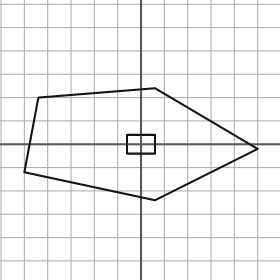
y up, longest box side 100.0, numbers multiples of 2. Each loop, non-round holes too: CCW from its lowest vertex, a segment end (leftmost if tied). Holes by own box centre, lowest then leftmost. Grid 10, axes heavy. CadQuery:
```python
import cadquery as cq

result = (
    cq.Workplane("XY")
    .moveTo(6.0, -24.0)
    .lineTo(50.0, -2.0)
    .lineTo(6.0, 24.0)
    .lineTo(-44.0, 20.0)
    .lineTo(-50.0, -12.0)
    .close()
    .moveTo(-6.0, -4.0)
    .lineTo(6.0, -4.0)
    .lineTo(6.0, 4.0)
    .lineTo(-6.0, 4.0)
    .close()
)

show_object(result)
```